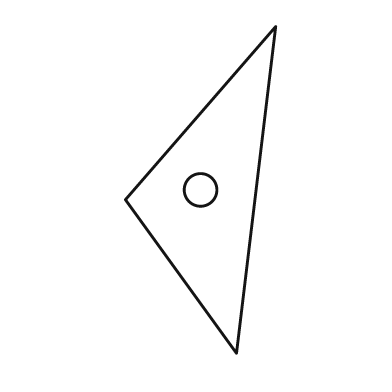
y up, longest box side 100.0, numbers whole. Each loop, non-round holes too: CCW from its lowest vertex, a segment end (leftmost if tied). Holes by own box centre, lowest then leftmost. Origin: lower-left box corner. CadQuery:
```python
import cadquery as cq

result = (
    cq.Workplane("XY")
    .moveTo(34.0, 0.0)
    .lineTo(46.0, 100.0)
    .lineTo(0.0, 47.0)
    .close()
    .moveTo(23.0, 50.0)
    .circle(5.0)
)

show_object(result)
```